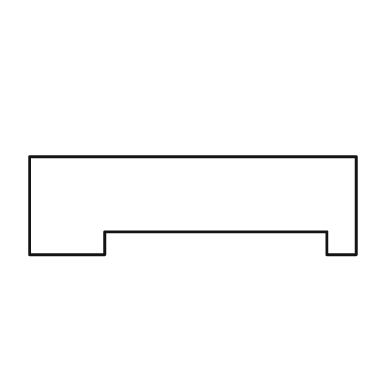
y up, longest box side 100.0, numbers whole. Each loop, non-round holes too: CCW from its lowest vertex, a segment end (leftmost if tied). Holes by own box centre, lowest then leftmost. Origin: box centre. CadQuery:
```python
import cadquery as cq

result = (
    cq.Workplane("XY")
    .moveTo(-50.0, -15.0)
    .lineTo(-27.0, -15.0)
    .lineTo(-27.0, -8.0)
    .lineTo(41.0, -8.0)
    .lineTo(41.0, -15.0)
    .lineTo(50.0, -15.0)
    .lineTo(50.0, 15.0)
    .lineTo(-50.0, 15.0)
    .close()
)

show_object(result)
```